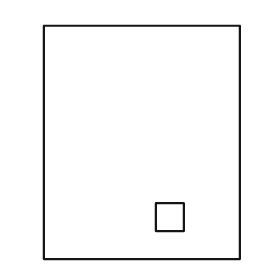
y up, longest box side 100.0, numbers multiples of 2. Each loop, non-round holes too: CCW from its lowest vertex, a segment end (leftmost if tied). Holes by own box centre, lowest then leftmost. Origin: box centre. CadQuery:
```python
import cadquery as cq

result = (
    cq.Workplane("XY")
    .moveTo(-42.0, -50.0)
    .lineTo(42.0, -50.0)
    .lineTo(42.0, 50.0)
    .lineTo(-42.0, 50.0)
    .close()
    .moveTo(6.0, -38.0)
    .lineTo(18.0, -38.0)
    .lineTo(18.0, -26.0)
    .lineTo(6.0, -26.0)
    .close()
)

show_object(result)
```